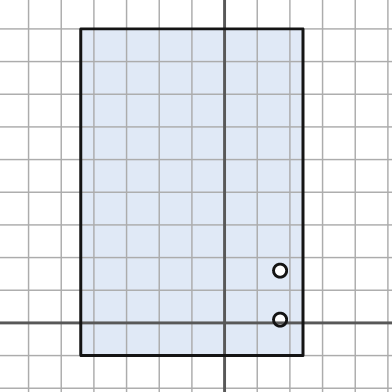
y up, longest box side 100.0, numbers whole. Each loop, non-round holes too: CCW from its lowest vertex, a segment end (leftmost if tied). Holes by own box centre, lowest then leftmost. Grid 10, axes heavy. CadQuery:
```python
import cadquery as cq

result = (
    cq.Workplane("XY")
    .moveTo(-44.0, -10.0)
    .lineTo(24.0, -10.0)
    .lineTo(24.0, 90.0)
    .lineTo(-44.0, 90.0)
    .close()
    .moveTo(17.0, 1.0)
    .circle(2.0)
    .moveTo(17.0, 16.0)
    .circle(2.0)
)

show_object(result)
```